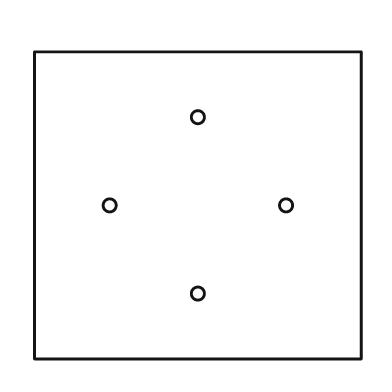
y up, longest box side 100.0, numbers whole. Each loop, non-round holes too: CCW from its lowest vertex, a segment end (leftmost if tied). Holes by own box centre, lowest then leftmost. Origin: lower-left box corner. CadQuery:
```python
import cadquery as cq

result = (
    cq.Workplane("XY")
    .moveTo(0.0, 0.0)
    .lineTo(100.0, 0.0)
    .lineTo(100.0, 94.0)
    .lineTo(0.0, 94.0)
    .close()
    .moveTo(50.0, 20.0)
    .circle(2.0)
    .moveTo(23.0, 47.0)
    .circle(2.0)
    .moveTo(77.0, 47.0)
    .circle(2.0)
    .moveTo(50.0, 74.0)
    .circle(2.0)
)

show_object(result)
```